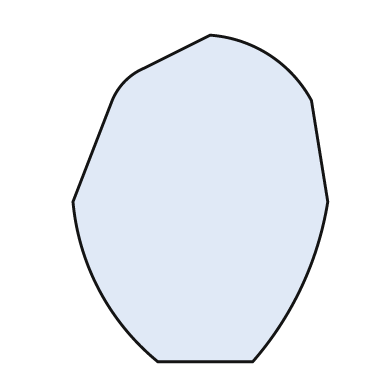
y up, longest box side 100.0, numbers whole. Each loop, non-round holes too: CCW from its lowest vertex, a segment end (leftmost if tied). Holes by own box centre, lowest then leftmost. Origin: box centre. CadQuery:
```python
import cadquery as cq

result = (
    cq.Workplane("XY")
    .moveTo(-13.0, -50.0)
    .lineTo(16.0, -50.0)
    .threePointArc((31.0, -27.0), (39.0, -1.0))
    .lineTo(34.0, 30.0)
    .threePointArc((21.0, 44.0), (3.0, 50.0))
    .lineTo(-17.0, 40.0)
    .threePointArc((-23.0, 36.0), (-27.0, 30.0))
    .lineTo(-39.0, -1.0)
    .threePointArc((-31.0, -28.0), (-13.0, -50.0))
    .close()
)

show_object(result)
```